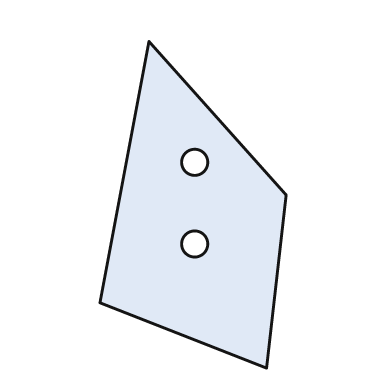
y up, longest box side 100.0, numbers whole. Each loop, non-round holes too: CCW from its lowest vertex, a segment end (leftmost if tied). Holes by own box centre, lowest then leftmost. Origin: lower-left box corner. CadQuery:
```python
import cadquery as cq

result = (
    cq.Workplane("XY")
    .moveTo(51.0, 0.0)
    .lineTo(57.0, 53.0)
    .lineTo(15.0, 100.0)
    .lineTo(0.0, 20.0)
    .close()
    .moveTo(29.0, 38.0)
    .circle(4.0)
    .moveTo(29.0, 63.0)
    .circle(4.0)
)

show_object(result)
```